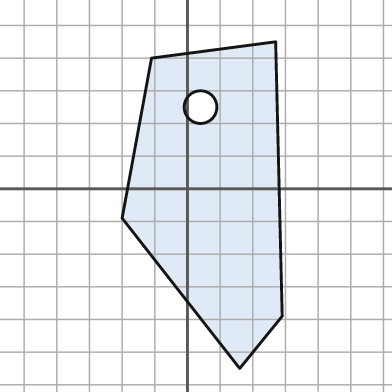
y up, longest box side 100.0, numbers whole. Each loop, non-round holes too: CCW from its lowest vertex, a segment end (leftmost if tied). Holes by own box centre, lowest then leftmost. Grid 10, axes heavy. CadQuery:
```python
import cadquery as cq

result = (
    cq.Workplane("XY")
    .moveTo(16.0, -55.0)
    .lineTo(29.0, -39.0)
    .lineTo(27.0, 45.0)
    .lineTo(-11.0, 40.0)
    .lineTo(-20.0, -9.0)
    .close()
    .moveTo(4.0, 25.0)
    .circle(5.0)
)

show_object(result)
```